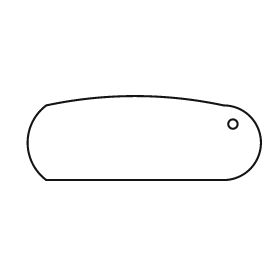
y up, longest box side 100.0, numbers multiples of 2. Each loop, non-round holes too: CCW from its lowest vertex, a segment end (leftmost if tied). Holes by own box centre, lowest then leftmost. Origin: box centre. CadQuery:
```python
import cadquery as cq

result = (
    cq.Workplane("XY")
    .moveTo(-42.0, -18.0)
    .lineTo(34.0, -18.0)
    .threePointArc((50.0, -2.0), (34.0, 14.0))
    .threePointArc((-4.0, 18.0), (-42.0, 14.0))
    .threePointArc((-50.0, -2.0), (-42.0, -18.0))
    .close()
    .moveTo(38.0, 6.0)
    .circle(2.0)
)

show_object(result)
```